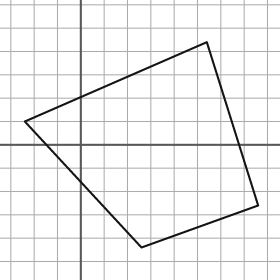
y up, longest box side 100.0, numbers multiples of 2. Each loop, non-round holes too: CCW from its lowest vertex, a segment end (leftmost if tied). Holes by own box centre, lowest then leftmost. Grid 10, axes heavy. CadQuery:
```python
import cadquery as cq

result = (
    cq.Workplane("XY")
    .moveTo(26.0, -44.0)
    .lineTo(76.0, -26.0)
    .lineTo(54.0, 44.0)
    .lineTo(-24.0, 10.0)
    .close()
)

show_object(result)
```